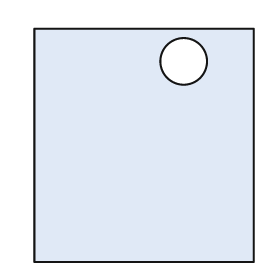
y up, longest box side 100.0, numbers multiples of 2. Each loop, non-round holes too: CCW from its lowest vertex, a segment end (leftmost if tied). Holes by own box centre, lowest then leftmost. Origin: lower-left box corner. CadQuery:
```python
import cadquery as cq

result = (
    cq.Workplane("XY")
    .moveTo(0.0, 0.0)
    .lineTo(94.0, 0.0)
    .lineTo(94.0, 100.0)
    .lineTo(0.0, 100.0)
    .close()
    .moveTo(64.0, 86.0)
    .circle(10.0)
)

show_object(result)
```